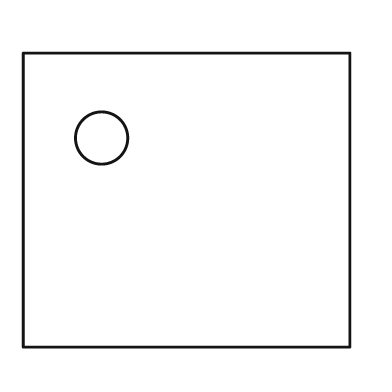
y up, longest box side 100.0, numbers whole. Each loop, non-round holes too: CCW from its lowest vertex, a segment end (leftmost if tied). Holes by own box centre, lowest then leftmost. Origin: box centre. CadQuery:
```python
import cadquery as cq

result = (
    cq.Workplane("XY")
    .moveTo(-50.0, -45.0)
    .lineTo(50.0, -45.0)
    .lineTo(50.0, 45.0)
    .lineTo(-50.0, 45.0)
    .close()
    .moveTo(-26.0, 19.0)
    .circle(8.0)
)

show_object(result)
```